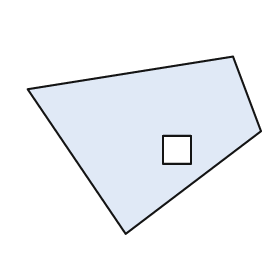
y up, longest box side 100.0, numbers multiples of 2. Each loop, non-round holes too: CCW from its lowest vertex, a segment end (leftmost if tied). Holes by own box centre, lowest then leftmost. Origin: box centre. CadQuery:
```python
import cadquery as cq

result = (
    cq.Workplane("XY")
    .moveTo(-8.0, -38.0)
    .lineTo(50.0, 6.0)
    .lineTo(38.0, 38.0)
    .lineTo(-50.0, 24.0)
    .close()
    .moveTo(8.0, -8.0)
    .lineTo(20.0, -8.0)
    .lineTo(20.0, 4.0)
    .lineTo(8.0, 4.0)
    .close()
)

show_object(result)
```